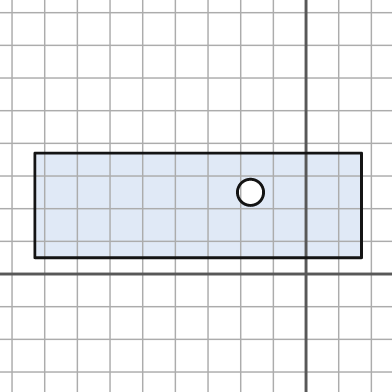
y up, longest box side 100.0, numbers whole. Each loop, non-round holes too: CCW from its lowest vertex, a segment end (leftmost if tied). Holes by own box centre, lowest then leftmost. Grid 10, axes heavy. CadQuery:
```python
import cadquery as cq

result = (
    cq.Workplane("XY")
    .moveTo(-83.0, 5.0)
    .lineTo(17.0, 5.0)
    .lineTo(17.0, 37.0)
    .lineTo(-83.0, 37.0)
    .close()
    .moveTo(-17.0, 25.0)
    .circle(4.0)
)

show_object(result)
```